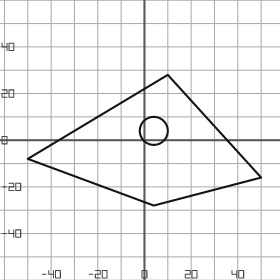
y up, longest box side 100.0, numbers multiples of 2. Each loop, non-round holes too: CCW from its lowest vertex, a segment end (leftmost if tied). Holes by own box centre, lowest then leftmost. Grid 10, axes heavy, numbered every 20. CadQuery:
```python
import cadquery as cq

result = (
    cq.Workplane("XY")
    .moveTo(4.0, -28.0)
    .lineTo(50.0, -16.0)
    .lineTo(10.0, 28.0)
    .lineTo(-50.0, -8.0)
    .close()
    .moveTo(4.0, 4.0)
    .circle(6.0)
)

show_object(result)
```